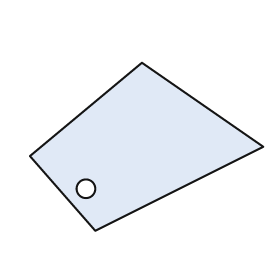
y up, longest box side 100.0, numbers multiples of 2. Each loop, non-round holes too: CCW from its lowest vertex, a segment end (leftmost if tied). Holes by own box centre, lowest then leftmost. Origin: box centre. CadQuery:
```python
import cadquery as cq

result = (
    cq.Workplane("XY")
    .moveTo(-22.0, -36.0)
    .lineTo(50.0, 0.0)
    .lineTo(-2.0, 36.0)
    .lineTo(-50.0, -4.0)
    .close()
    .moveTo(-26.0, -18.0)
    .circle(4.0)
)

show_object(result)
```